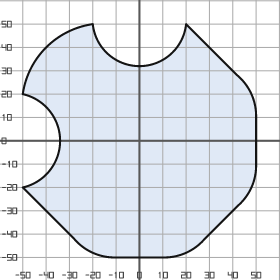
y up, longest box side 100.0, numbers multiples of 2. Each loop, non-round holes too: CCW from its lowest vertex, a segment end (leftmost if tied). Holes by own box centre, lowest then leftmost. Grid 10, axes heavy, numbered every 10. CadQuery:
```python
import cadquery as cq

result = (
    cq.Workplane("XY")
    .moveTo(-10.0, -50.0)
    .lineTo(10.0, -50.0)
    .threePointArc((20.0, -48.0), (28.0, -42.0))
    .lineTo(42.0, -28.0)
    .threePointArc((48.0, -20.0), (50.0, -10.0))
    .lineTo(50.0, 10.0)
    .threePointArc((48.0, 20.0), (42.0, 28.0))
    .lineTo(20.0, 50.0)
    .threePointArc((0.0, 32.0), (-20.0, 50.0))
    .threePointArc((-40.0, 40.0), (-50.0, 20.0))
    .threePointArc((-34.0, 0.0), (-50.0, -20.0))
    .lineTo(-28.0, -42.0)
    .threePointArc((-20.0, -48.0), (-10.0, -50.0))
    .close()
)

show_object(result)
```